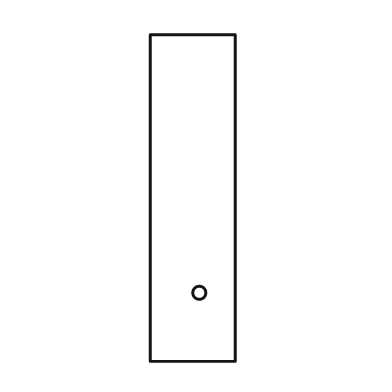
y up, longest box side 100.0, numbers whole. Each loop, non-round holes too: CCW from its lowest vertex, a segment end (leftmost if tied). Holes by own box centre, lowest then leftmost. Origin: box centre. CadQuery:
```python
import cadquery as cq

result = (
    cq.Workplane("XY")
    .moveTo(-13.0, -50.0)
    .lineTo(13.0, -50.0)
    .lineTo(13.0, 50.0)
    .lineTo(-13.0, 50.0)
    .close()
    .moveTo(2.0, -29.0)
    .circle(2.0)
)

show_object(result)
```